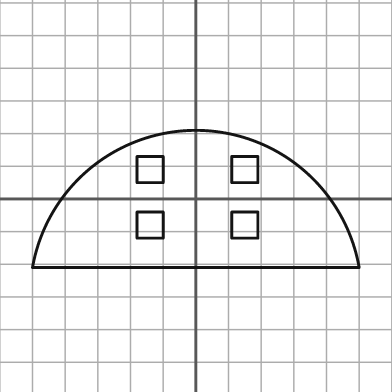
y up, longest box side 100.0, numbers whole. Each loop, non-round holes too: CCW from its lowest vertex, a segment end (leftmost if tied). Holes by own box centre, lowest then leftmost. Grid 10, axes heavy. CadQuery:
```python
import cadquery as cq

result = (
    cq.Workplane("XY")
    .moveTo(-50.0, -21.0)
    .lineTo(50.0, -21.0)
    .threePointArc((0.0, 21.0), (-50.0, -21.0))
    .close()
    .moveTo(-18.0, -12.0)
    .lineTo(-10.0, -12.0)
    .lineTo(-10.0, -4.0)
    .lineTo(-18.0, -4.0)
    .close()
    .moveTo(11.0, -12.0)
    .lineTo(19.0, -12.0)
    .lineTo(19.0, -4.0)
    .lineTo(11.0, -4.0)
    .close()
    .moveTo(-18.0, 5.0)
    .lineTo(-10.0, 5.0)
    .lineTo(-10.0, 13.0)
    .lineTo(-18.0, 13.0)
    .close()
    .moveTo(11.0, 5.0)
    .lineTo(19.0, 5.0)
    .lineTo(19.0, 13.0)
    .lineTo(11.0, 13.0)
    .close()
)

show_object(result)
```